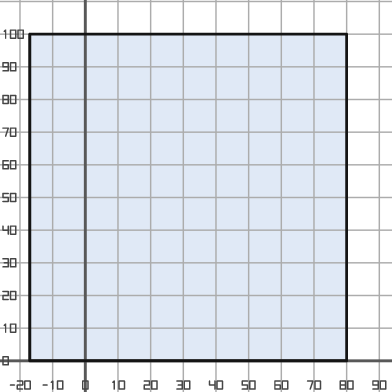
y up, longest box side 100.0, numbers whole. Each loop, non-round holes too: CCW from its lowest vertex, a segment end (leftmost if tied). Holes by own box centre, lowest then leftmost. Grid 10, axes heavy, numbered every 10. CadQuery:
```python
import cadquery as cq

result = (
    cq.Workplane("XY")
    .moveTo(-17.0, 0.0)
    .lineTo(80.0, 0.0)
    .lineTo(80.0, 100.0)
    .lineTo(-17.0, 100.0)
    .close()
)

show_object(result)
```